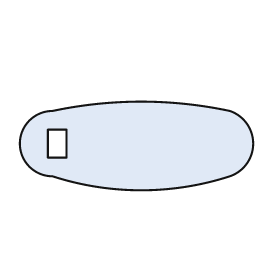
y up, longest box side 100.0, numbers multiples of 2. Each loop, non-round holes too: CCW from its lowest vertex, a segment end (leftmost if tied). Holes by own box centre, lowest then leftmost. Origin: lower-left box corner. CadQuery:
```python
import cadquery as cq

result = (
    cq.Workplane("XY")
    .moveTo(14.0, 6.0)
    .threePointArc((52.0, 0.0), (90.0, 6.0))
    .threePointArc((100.0, 20.0), (90.0, 34.0))
    .threePointArc((52.0, 38.0), (14.0, 34.0))
    .threePointArc((0.0, 20.0), (14.0, 6.0))
    .close()
    .moveTo(12.0, 14.0)
    .lineTo(20.0, 14.0)
    .lineTo(20.0, 26.0)
    .lineTo(12.0, 26.0)
    .close()
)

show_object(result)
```